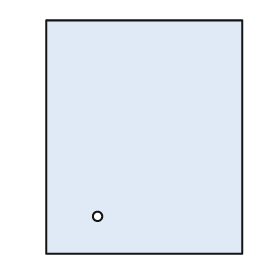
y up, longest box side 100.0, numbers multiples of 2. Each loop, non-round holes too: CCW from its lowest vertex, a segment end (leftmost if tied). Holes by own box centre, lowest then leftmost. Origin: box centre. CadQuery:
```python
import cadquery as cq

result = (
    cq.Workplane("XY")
    .moveTo(-42.0, -50.0)
    .lineTo(42.0, -50.0)
    .lineTo(42.0, 50.0)
    .lineTo(-42.0, 50.0)
    .close()
    .moveTo(-20.0, -34.0)
    .circle(2.0)
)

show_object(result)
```